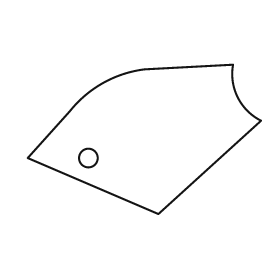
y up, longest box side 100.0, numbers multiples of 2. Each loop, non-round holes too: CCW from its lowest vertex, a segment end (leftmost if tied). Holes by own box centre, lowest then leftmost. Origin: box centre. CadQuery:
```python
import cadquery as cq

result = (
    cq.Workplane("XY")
    .moveTo(6.0, -32.0)
    .lineTo(50.0, 8.0)
    .threePointArc((40.0, 18.0), (38.0, 32.0))
    .lineTo(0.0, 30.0)
    .threePointArc((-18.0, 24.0), (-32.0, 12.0))
    .lineTo(-50.0, -8.0)
    .close()
    .moveTo(-24.0, -8.0)
    .circle(4.0)
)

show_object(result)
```